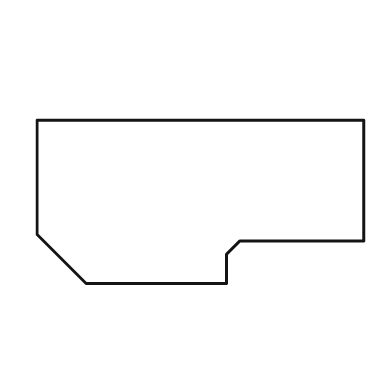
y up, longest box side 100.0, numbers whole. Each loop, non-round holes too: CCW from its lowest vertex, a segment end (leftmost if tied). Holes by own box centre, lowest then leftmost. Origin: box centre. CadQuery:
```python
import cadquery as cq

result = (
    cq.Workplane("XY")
    .moveTo(-35.0, -25.0)
    .lineTo(8.0, -25.0)
    .lineTo(8.0, -16.0)
    .lineTo(12.0, -12.0)
    .lineTo(50.0, -12.0)
    .lineTo(50.0, 25.0)
    .lineTo(-50.0, 25.0)
    .lineTo(-50.0, -10.0)
    .close()
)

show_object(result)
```